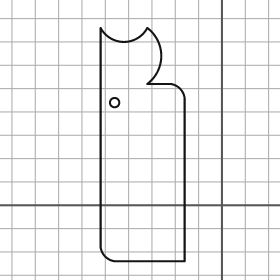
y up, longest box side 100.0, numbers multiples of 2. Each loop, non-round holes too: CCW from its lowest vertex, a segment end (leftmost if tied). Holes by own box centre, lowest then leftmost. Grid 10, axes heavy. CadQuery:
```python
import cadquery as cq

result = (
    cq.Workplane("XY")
    .moveTo(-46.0, -24.0)
    .lineTo(-16.0, -24.0)
    .lineTo(-16.0, 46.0)
    .threePointArc((-18.0, 50.0), (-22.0, 52.0))
    .lineTo(-32.0, 52.0)
    .threePointArc((-26.0, 64.0), (-32.0, 76.0))
    .threePointArc((-42.0, 70.0), (-52.0, 76.0))
    .lineTo(-52.0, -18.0)
    .threePointArc((-50.0, -22.0), (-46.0, -24.0))
    .close()
    .moveTo(-46.0, 44.0)
    .circle(2.0)
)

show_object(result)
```